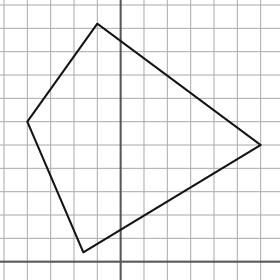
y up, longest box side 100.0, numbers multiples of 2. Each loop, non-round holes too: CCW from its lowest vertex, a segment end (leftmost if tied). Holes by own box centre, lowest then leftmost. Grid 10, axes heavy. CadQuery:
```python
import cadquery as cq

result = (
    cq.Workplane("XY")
    .moveTo(-16.0, 4.0)
    .lineTo(60.0, 50.0)
    .lineTo(-10.0, 102.0)
    .lineTo(-40.0, 60.0)
    .close()
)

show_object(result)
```